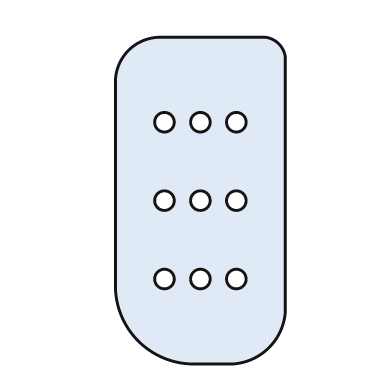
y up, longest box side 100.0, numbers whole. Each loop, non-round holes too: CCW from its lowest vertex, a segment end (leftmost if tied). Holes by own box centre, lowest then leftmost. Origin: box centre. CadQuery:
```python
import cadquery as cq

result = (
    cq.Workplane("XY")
    .moveTo(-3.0, -50.0)
    .lineTo(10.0, -50.0)
    .threePointArc((21.0, -45.0), (26.0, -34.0))
    .lineTo(26.0, 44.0)
    .threePointArc((24.0, 48.0), (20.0, 50.0))
    .lineTo(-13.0, 50.0)
    .threePointArc((-22.0, 46.0), (-26.0, 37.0))
    .lineTo(-26.0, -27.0)
    .threePointArc((-19.0, -43.0), (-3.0, -50.0))
    .close()
    .moveTo(-11.0, -24.0)
    .circle(3.0)
    .moveTo(0.0, -24.0)
    .circle(3.0)
    .moveTo(11.0, -24.0)
    .circle(3.0)
    .moveTo(-11.0, 0.0)
    .circle(3.0)
    .moveTo(0.0, 0.0)
    .circle(3.0)
    .moveTo(11.0, 0.0)
    .circle(3.0)
    .moveTo(-11.0, 24.0)
    .circle(3.0)
    .moveTo(0.0, 24.0)
    .circle(3.0)
    .moveTo(11.0, 24.0)
    .circle(3.0)
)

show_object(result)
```